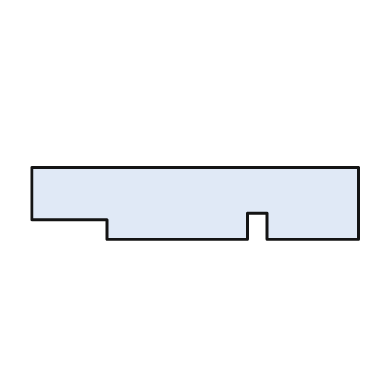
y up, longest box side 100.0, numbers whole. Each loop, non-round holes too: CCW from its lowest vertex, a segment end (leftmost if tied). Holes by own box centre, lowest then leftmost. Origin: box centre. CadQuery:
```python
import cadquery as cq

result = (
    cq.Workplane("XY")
    .moveTo(-27.0, -11.0)
    .lineTo(16.0, -11.0)
    .lineTo(16.0, -3.0)
    .lineTo(22.0, -3.0)
    .lineTo(22.0, -11.0)
    .lineTo(50.0, -11.0)
    .lineTo(50.0, 11.0)
    .lineTo(-50.0, 11.0)
    .lineTo(-50.0, -5.0)
    .lineTo(-27.0, -5.0)
    .close()
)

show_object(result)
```